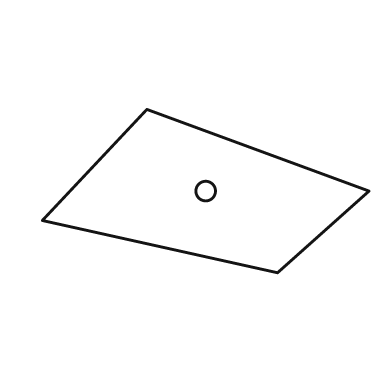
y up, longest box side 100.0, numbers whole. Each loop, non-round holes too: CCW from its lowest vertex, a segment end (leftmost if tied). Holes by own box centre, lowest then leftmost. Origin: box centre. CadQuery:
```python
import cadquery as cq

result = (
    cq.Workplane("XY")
    .moveTo(22.0, -25.0)
    .lineTo(50.0, 0.0)
    .lineTo(-18.0, 25.0)
    .lineTo(-50.0, -9.0)
    .close()
    .moveTo(0.0, 0.0)
    .circle(3.0)
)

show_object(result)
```